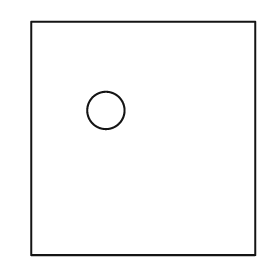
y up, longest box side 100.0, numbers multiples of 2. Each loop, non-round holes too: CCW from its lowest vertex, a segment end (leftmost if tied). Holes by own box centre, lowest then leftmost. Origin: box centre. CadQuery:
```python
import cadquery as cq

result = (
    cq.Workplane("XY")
    .moveTo(-48.0, -50.0)
    .lineTo(48.0, -50.0)
    .lineTo(48.0, 50.0)
    .lineTo(-48.0, 50.0)
    .close()
    .moveTo(-16.0, 12.0)
    .circle(8.0)
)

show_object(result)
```